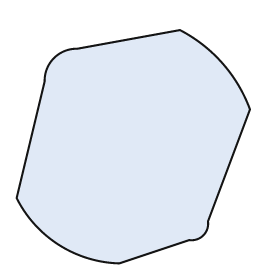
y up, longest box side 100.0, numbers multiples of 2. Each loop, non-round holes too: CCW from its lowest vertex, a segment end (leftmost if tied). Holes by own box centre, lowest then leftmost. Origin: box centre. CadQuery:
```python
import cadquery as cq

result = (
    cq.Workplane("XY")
    .moveTo(-6.0, -50.0)
    .lineTo(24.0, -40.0)
    .threePointArc((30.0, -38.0), (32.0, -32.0))
    .lineTo(50.0, 16.0)
    .threePointArc((38.0, 36.0), (20.0, 50.0))
    .lineTo(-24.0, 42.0)
    .threePointArc((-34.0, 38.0), (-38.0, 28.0))
    .lineTo(-50.0, -22.0)
    .threePointArc((-32.0, -42.0), (-6.0, -50.0))
    .close()
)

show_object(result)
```